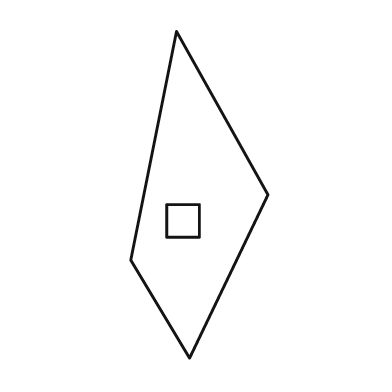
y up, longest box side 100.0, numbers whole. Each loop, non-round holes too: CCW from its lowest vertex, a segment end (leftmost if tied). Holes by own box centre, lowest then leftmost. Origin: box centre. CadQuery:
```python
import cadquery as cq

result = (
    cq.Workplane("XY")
    .moveTo(-3.0, -50.0)
    .lineTo(21.0, 0.0)
    .lineTo(-7.0, 50.0)
    .lineTo(-21.0, -20.0)
    .close()
    .moveTo(-10.0, -13.0)
    .lineTo(0.0, -13.0)
    .lineTo(0.0, -3.0)
    .lineTo(-10.0, -3.0)
    .close()
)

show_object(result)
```